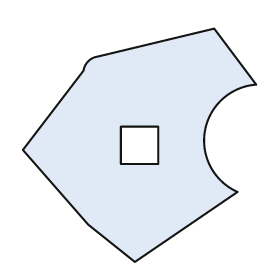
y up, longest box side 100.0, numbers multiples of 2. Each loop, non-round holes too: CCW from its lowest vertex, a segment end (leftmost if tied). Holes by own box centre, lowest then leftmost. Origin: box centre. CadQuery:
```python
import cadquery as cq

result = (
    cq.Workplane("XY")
    .moveTo(-2.0, -50.0)
    .lineTo(42.0, -20.0)
    .threePointArc((28.0, 6.0), (50.0, 26.0))
    .lineTo(32.0, 50.0)
    .lineTo(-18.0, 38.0)
    .threePointArc((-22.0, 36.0), (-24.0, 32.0))
    .lineTo(-50.0, -2.0)
    .lineTo(-22.0, -34.0)
    .close()
    .moveTo(-8.0, -8.0)
    .lineTo(8.0, -8.0)
    .lineTo(8.0, 8.0)
    .lineTo(-8.0, 8.0)
    .close()
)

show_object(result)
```